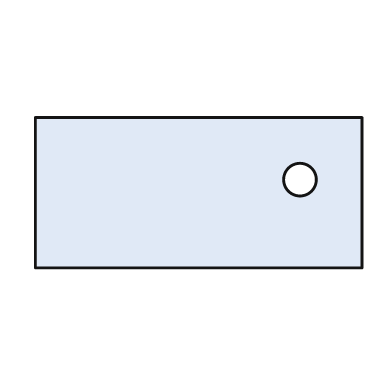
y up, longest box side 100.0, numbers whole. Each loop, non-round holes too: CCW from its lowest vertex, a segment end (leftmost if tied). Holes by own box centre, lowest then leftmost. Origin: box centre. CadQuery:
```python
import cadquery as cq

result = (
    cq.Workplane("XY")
    .moveTo(-50.0, -23.0)
    .lineTo(50.0, -23.0)
    .lineTo(50.0, 23.0)
    .lineTo(-50.0, 23.0)
    .close()
    .moveTo(31.0, 4.0)
    .circle(5.0)
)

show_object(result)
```